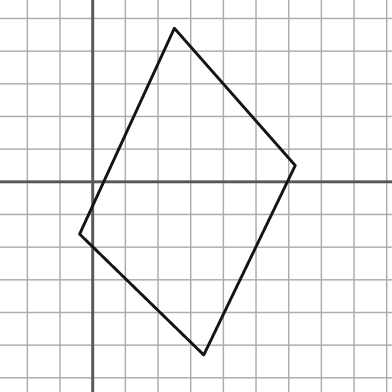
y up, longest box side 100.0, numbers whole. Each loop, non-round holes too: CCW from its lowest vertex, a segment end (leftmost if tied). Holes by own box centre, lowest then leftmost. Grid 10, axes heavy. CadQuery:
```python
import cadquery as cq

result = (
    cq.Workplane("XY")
    .moveTo(34.0, -53.0)
    .lineTo(62.0, 5.0)
    .lineTo(25.0, 47.0)
    .lineTo(-4.0, -16.0)
    .close()
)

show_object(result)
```